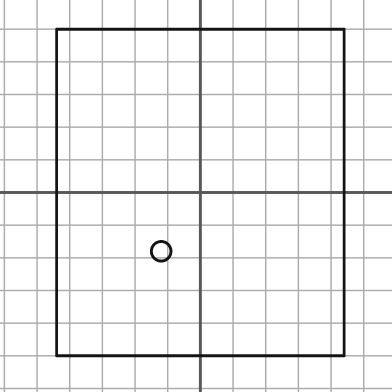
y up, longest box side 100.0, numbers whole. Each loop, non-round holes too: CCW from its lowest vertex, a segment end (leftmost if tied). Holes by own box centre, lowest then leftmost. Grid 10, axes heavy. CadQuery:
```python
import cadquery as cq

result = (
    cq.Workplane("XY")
    .moveTo(-44.0, -50.0)
    .lineTo(44.0, -50.0)
    .lineTo(44.0, 50.0)
    .lineTo(-44.0, 50.0)
    .close()
    .moveTo(-12.0, -18.0)
    .circle(3.0)
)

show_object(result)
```